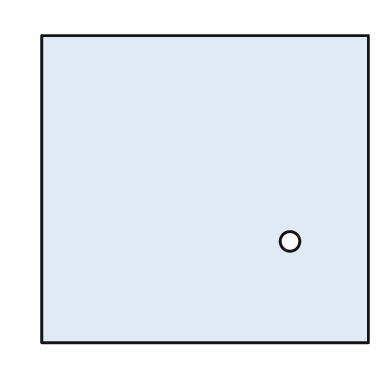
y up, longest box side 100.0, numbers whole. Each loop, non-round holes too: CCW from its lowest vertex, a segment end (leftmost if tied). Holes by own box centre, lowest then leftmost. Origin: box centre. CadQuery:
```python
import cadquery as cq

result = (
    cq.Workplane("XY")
    .moveTo(-50.0, -47.0)
    .lineTo(50.0, -47.0)
    .lineTo(50.0, 47.0)
    .lineTo(-50.0, 47.0)
    .close()
    .moveTo(26.0, -16.0)
    .circle(3.0)
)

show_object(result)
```